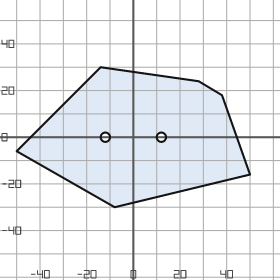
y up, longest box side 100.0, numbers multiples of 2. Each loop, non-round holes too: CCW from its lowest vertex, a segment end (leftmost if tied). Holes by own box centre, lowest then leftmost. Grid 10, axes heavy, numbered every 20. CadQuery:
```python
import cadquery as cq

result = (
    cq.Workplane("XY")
    .moveTo(-8.0, -30.0)
    .lineTo(50.0, -16.0)
    .lineTo(38.0, 18.0)
    .lineTo(28.0, 24.0)
    .lineTo(-14.0, 30.0)
    .lineTo(-50.0, -6.0)
    .close()
    .moveTo(-12.0, 0.0)
    .circle(2.0)
    .moveTo(12.0, 0.0)
    .circle(2.0)
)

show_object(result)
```